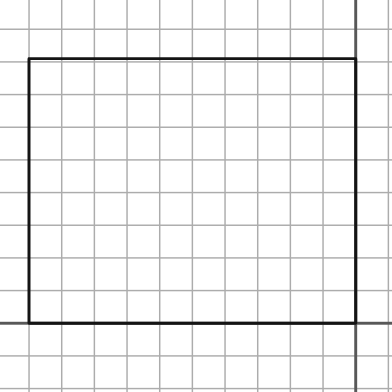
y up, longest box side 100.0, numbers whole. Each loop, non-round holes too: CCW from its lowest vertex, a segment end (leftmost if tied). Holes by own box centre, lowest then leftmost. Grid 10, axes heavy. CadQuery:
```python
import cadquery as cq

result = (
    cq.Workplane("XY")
    .moveTo(-100.0, 0.0)
    .lineTo(0.0, 0.0)
    .lineTo(0.0, 81.0)
    .lineTo(-100.0, 81.0)
    .close()
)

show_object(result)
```